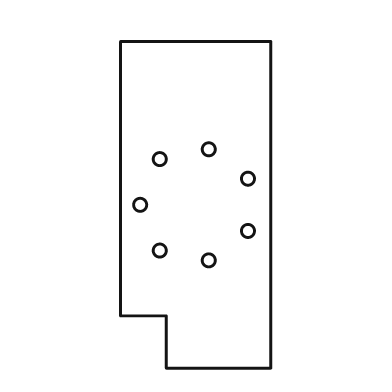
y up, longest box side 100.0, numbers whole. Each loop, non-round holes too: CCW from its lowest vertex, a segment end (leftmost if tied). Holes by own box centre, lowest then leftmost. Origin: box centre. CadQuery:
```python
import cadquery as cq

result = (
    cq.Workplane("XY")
    .moveTo(-9.0, -50.0)
    .lineTo(23.0, -50.0)
    .lineTo(23.0, 50.0)
    .lineTo(-23.0, 50.0)
    .lineTo(-23.0, -34.0)
    .lineTo(-9.0, -34.0)
    .close()
    .moveTo(4.0, -17.0)
    .circle(2.0)
    .moveTo(-11.0, -14.0)
    .circle(2.0)
    .moveTo(16.0, -8.0)
    .circle(2.0)
    .moveTo(-17.0, 0.0)
    .circle(2.0)
    .moveTo(16.0, 8.0)
    .circle(2.0)
    .moveTo(-11.0, 14.0)
    .circle(2.0)
    .moveTo(4.0, 17.0)
    .circle(2.0)
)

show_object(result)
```